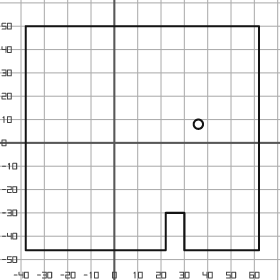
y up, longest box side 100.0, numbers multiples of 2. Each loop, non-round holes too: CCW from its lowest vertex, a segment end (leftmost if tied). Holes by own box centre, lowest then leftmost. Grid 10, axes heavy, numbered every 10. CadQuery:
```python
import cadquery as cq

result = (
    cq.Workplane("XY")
    .moveTo(-38.0, -46.0)
    .lineTo(22.0, -46.0)
    .lineTo(22.0, -30.0)
    .lineTo(30.0, -30.0)
    .lineTo(30.0, -46.0)
    .lineTo(62.0, -46.0)
    .lineTo(62.0, 50.0)
    .lineTo(-38.0, 50.0)
    .close()
    .moveTo(36.0, 8.0)
    .circle(2.0)
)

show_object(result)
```